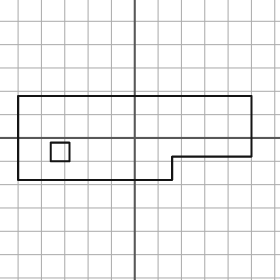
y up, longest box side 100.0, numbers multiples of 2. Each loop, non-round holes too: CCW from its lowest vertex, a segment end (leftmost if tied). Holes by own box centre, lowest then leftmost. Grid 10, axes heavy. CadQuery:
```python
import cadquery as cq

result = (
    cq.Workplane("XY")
    .moveTo(-50.0, -18.0)
    .lineTo(16.0, -18.0)
    .lineTo(16.0, -8.0)
    .lineTo(50.0, -8.0)
    .lineTo(50.0, 18.0)
    .lineTo(-50.0, 18.0)
    .close()
    .moveTo(-36.0, -10.0)
    .lineTo(-28.0, -10.0)
    .lineTo(-28.0, -2.0)
    .lineTo(-36.0, -2.0)
    .close()
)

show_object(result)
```